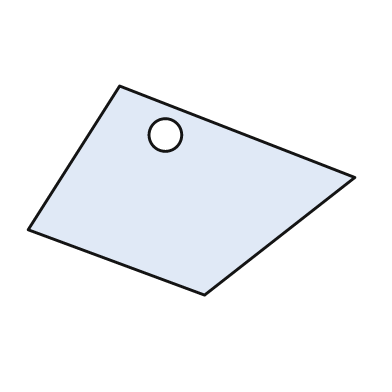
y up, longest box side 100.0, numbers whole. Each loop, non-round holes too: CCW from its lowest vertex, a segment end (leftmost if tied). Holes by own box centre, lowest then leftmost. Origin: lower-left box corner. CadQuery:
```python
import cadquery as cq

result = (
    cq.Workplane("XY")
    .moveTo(54.0, 0.0)
    .lineTo(100.0, 36.0)
    .lineTo(28.0, 64.0)
    .lineTo(0.0, 20.0)
    .close()
    .moveTo(42.0, 49.0)
    .circle(5.0)
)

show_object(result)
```